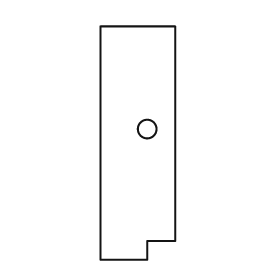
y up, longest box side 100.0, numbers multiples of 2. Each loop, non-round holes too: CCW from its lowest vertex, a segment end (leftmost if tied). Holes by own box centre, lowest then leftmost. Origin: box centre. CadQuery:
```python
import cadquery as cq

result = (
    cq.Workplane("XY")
    .moveTo(-16.0, -50.0)
    .lineTo(4.0, -50.0)
    .lineTo(4.0, -42.0)
    .lineTo(16.0, -42.0)
    .lineTo(16.0, 50.0)
    .lineTo(-16.0, 50.0)
    .close()
    .moveTo(4.0, 6.0)
    .circle(4.0)
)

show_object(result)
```